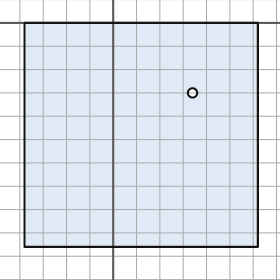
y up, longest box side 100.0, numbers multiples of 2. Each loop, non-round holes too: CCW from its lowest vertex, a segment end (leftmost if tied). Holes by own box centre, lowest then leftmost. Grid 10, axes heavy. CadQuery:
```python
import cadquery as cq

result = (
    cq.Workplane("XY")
    .moveTo(-38.0, -96.0)
    .lineTo(62.0, -96.0)
    .lineTo(62.0, 0.0)
    .lineTo(-38.0, 0.0)
    .close()
    .moveTo(34.0, -30.0)
    .circle(2.0)
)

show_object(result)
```